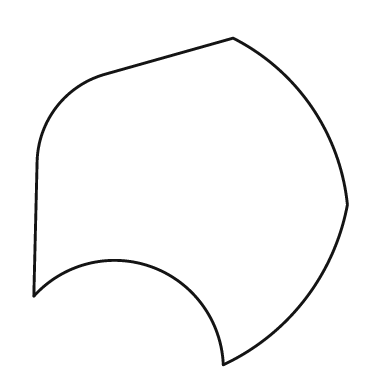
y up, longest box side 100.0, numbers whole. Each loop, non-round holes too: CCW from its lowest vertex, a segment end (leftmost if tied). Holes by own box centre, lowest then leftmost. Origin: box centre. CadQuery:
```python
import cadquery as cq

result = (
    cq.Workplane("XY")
    .moveTo(10.0, -50.0)
    .threePointArc((35.0, -30.0), (48.0, -1.0))
    .threePointArc((37.0, 29.0), (13.0, 50.0))
    .lineTo(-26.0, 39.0)
    .threePointArc((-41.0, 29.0), (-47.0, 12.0))
    .lineTo(-48.0, -29.0)
    .threePointArc((-12.0, -20.0), (10.0, -50.0))
    .close()
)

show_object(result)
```